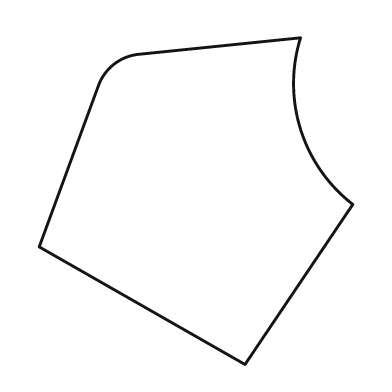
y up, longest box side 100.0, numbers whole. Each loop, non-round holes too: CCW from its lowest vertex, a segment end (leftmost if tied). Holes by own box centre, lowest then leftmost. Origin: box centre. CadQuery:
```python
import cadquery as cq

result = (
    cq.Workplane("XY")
    .moveTo(15.0, -50.0)
    .lineTo(48.0, -1.0)
    .threePointArc((32.0, 22.0), (32.0, 50.0))
    .lineTo(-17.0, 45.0)
    .threePointArc((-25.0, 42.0), (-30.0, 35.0))
    .lineTo(-48.0, -14.0)
    .close()
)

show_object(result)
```